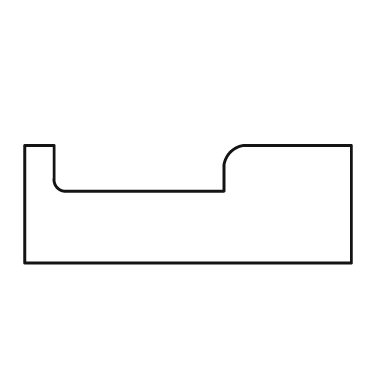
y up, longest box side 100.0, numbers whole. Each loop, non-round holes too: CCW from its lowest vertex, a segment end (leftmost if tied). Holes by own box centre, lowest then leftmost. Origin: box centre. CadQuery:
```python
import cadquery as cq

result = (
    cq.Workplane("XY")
    .moveTo(-50.0, -18.0)
    .lineTo(50.0, -18.0)
    .lineTo(50.0, 18.0)
    .lineTo(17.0, 18.0)
    .threePointArc((13.0, 16.0), (11.0, 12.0))
    .lineTo(11.0, 4.0)
    .lineTo(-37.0, 4.0)
    .threePointArc((-40.0, 5.0), (-41.0, 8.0))
    .lineTo(-41.0, 18.0)
    .lineTo(-50.0, 18.0)
    .close()
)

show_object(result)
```